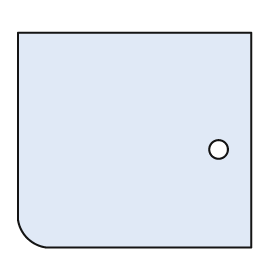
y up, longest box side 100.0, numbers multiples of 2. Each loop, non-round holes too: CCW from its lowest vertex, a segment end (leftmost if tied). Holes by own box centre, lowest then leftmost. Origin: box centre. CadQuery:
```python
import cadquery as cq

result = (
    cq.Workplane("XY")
    .moveTo(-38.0, -46.0)
    .lineTo(50.0, -46.0)
    .lineTo(50.0, 46.0)
    .lineTo(-50.0, 46.0)
    .lineTo(-50.0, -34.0)
    .threePointArc((-46.0, -42.0), (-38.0, -46.0))
    .close()
    .moveTo(36.0, -4.0)
    .circle(4.0)
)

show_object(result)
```